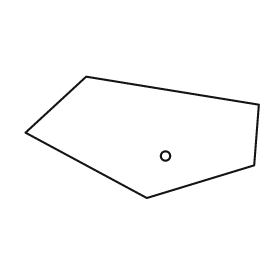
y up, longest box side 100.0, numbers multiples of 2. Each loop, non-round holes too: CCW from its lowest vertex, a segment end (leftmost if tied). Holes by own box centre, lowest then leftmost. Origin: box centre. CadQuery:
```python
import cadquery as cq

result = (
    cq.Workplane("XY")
    .moveTo(2.0, -26.0)
    .lineTo(48.0, -12.0)
    .lineTo(50.0, 14.0)
    .lineTo(-24.0, 26.0)
    .lineTo(-50.0, 2.0)
    .close()
    .moveTo(10.0, -8.0)
    .circle(2.0)
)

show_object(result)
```